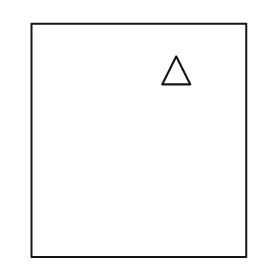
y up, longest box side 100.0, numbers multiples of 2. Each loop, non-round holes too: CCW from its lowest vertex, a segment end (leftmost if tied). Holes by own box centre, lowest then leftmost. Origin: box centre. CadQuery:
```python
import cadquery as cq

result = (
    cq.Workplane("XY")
    .moveTo(-46.0, -50.0)
    .lineTo(46.0, -50.0)
    .lineTo(46.0, 50.0)
    .lineTo(-46.0, 50.0)
    .close()
    .moveTo(10.0, 24.0)
    .lineTo(22.0, 24.0)
    .lineTo(16.0, 36.0)
    .close()
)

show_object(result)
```